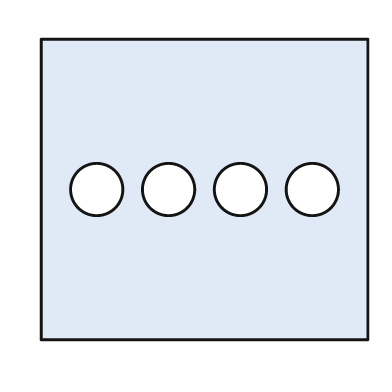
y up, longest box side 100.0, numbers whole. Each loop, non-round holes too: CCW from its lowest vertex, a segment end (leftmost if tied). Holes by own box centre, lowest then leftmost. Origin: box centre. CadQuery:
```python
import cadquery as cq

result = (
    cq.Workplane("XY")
    .moveTo(-50.0, -46.0)
    .lineTo(50.0, -46.0)
    .lineTo(50.0, 46.0)
    .lineTo(-50.0, 46.0)
    .close()
    .moveTo(-33.0, 0.0)
    .circle(8.0)
    .moveTo(-11.0, 0.0)
    .circle(8.0)
    .moveTo(11.0, 0.0)
    .circle(8.0)
    .moveTo(33.0, 0.0)
    .circle(8.0)
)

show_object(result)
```